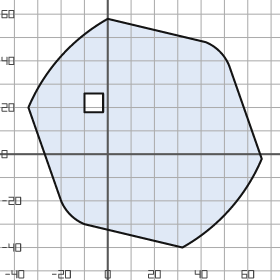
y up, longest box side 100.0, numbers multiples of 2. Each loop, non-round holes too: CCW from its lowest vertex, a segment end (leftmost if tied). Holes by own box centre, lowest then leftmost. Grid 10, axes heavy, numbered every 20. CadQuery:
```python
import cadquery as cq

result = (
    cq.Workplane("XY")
    .moveTo(32.0, -40.0)
    .threePointArc((52.0, -24.0), (66.0, -2.0))
    .lineTo(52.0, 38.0)
    .threePointArc((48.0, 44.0), (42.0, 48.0))
    .lineTo(0.0, 58.0)
    .threePointArc((-20.0, 42.0), (-34.0, 20.0))
    .lineTo(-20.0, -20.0)
    .threePointArc((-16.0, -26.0), (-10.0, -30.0))
    .close()
    .moveTo(-10.0, 18.0)
    .lineTo(-2.0, 18.0)
    .lineTo(-2.0, 26.0)
    .lineTo(-10.0, 26.0)
    .close()
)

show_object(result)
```